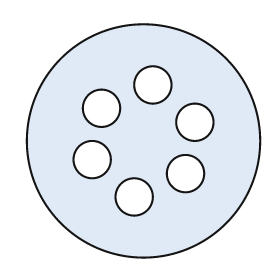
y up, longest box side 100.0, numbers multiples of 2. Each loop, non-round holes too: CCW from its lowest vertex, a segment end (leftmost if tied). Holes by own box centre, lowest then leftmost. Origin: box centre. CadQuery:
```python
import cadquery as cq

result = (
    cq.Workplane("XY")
    .moveTo(0.0, 0.0)
    .circle(50.0)
    .moveTo(-4.0, -24.0)
    .circle(8.0)
    .moveTo(18.0, -14.0)
    .circle(8.0)
    .moveTo(-22.0, -8.0)
    .circle(8.0)
    .moveTo(22.0, 8.0)
    .circle(8.0)
    .moveTo(-18.0, 14.0)
    .circle(8.0)
    .moveTo(4.0, 24.0)
    .circle(8.0)
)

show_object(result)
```